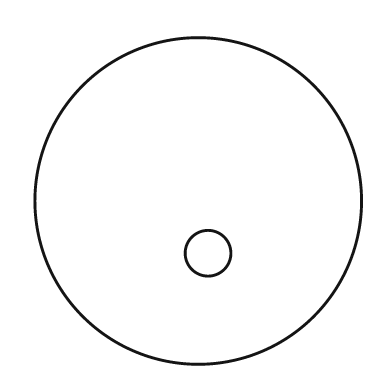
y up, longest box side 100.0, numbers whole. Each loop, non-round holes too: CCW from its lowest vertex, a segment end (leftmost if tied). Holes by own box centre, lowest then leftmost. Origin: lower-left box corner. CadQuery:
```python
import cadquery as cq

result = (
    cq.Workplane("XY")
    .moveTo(50.0, 50.0)
    .circle(50.0)
    .moveTo(53.0, 34.0)
    .circle(7.0)
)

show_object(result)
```